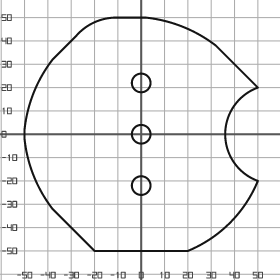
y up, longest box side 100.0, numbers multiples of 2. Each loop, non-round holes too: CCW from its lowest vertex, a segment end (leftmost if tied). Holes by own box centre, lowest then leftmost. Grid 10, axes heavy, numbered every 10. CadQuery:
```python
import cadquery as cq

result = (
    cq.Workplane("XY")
    .moveTo(-20.0, -50.0)
    .lineTo(20.0, -50.0)
    .threePointArc((38.0, -38.0), (50.0, -20.0))
    .threePointArc((36.0, 0.0), (50.0, 20.0))
    .lineTo(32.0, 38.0)
    .threePointArc((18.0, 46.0), (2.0, 50.0))
    .lineTo(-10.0, 50.0)
    .threePointArc((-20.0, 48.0), (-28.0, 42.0))
    .lineTo(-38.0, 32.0)
    .threePointArc((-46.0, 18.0), (-50.0, 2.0))
    .lineTo(-50.0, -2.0)
    .threePointArc((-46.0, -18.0), (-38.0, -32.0))
    .close()
    .moveTo(0.0, -22.0)
    .circle(4.0)
    .moveTo(0.0, 0.0)
    .circle(4.0)
    .moveTo(0.0, 22.0)
    .circle(4.0)
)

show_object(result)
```